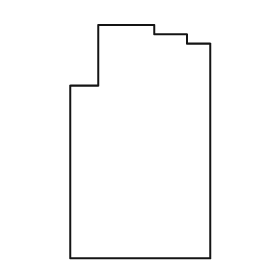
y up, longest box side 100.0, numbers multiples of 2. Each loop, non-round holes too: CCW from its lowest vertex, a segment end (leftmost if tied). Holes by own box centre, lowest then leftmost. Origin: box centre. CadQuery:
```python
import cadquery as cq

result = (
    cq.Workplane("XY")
    .moveTo(-30.0, -50.0)
    .lineTo(30.0, -50.0)
    .lineTo(30.0, 42.0)
    .lineTo(20.0, 42.0)
    .lineTo(20.0, 46.0)
    .lineTo(6.0, 46.0)
    .lineTo(6.0, 50.0)
    .lineTo(-18.0, 50.0)
    .lineTo(-18.0, 24.0)
    .lineTo(-30.0, 24.0)
    .close()
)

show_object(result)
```